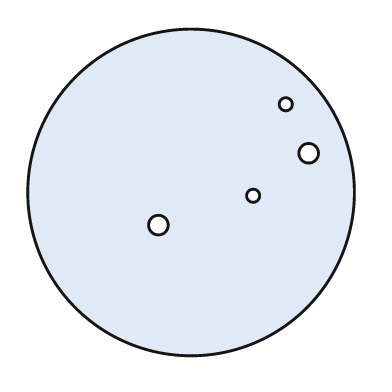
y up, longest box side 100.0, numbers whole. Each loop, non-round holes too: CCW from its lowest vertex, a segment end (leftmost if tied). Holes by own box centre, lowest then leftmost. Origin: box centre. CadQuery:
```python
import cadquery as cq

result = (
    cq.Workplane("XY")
    .moveTo(0.0, 0.0)
    .circle(50.0)
    .moveTo(-10.0, -10.0)
    .circle(3.0)
    .moveTo(19.0, -1.0)
    .circle(2.0)
    .moveTo(36.0, 12.0)
    .circle(3.0)
    .moveTo(29.0, 27.0)
    .circle(2.0)
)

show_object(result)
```